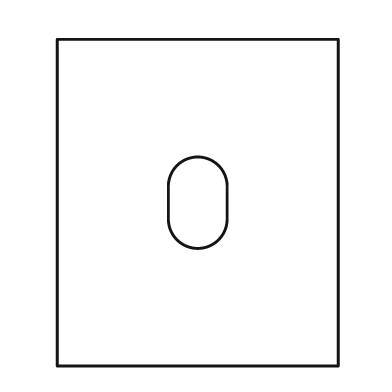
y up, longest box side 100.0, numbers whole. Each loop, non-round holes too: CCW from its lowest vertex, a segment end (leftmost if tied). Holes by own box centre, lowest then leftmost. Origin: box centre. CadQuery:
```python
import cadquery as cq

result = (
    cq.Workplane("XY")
    .moveTo(-43.0, -50.0)
    .lineTo(43.0, -50.0)
    .lineTo(43.0, 50.0)
    .lineTo(-43.0, 50.0)
    .close()
    .moveTo(-9.0, -5.0)
    .threePointArc((0.0, -14.0), (9.0, -5.0))
    .lineTo(9.0, 5.0)
    .threePointArc((0.0, 14.0), (-9.0, 5.0))
    .close()
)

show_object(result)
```